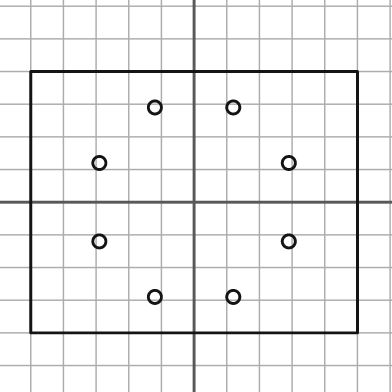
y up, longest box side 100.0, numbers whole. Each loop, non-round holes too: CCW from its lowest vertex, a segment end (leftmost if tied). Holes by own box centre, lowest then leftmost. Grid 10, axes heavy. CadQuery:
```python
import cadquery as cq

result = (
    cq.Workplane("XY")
    .moveTo(-50.0, -40.0)
    .lineTo(50.0, -40.0)
    .lineTo(50.0, 40.0)
    .lineTo(-50.0, 40.0)
    .close()
    .moveTo(-12.0, -29.0)
    .circle(2.0)
    .moveTo(12.0, -29.0)
    .circle(2.0)
    .moveTo(-29.0, -12.0)
    .circle(2.0)
    .moveTo(29.0, -12.0)
    .circle(2.0)
    .moveTo(-29.0, 12.0)
    .circle(2.0)
    .moveTo(29.0, 12.0)
    .circle(2.0)
    .moveTo(-12.0, 29.0)
    .circle(2.0)
    .moveTo(12.0, 29.0)
    .circle(2.0)
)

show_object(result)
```